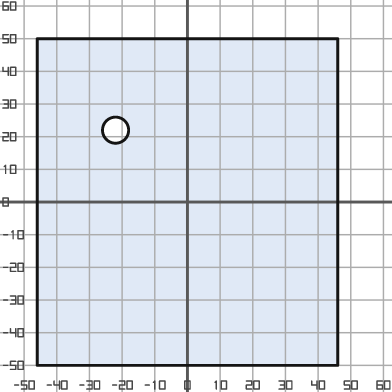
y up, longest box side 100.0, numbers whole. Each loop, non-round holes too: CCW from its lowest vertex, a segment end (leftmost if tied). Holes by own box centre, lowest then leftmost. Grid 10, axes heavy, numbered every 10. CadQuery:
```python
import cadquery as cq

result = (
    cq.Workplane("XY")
    .moveTo(-46.0, -50.0)
    .lineTo(46.0, -50.0)
    .lineTo(46.0, 50.0)
    .lineTo(-46.0, 50.0)
    .close()
    .moveTo(-22.0, 22.0)
    .circle(4.0)
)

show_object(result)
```